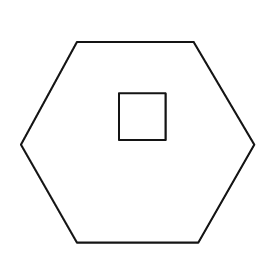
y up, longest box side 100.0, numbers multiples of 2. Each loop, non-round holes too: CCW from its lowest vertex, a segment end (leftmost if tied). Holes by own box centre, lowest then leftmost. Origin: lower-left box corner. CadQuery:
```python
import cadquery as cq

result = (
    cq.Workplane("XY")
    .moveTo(24.0, 0.0)
    .lineTo(76.0, 0.0)
    .lineTo(100.0, 42.0)
    .lineTo(74.0, 86.0)
    .lineTo(24.0, 86.0)
    .lineTo(0.0, 42.0)
    .close()
    .moveTo(42.0, 44.0)
    .lineTo(62.0, 44.0)
    .lineTo(62.0, 64.0)
    .lineTo(42.0, 64.0)
    .close()
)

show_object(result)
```